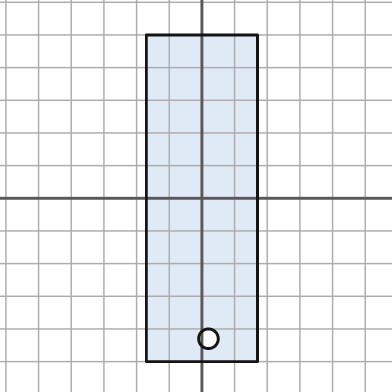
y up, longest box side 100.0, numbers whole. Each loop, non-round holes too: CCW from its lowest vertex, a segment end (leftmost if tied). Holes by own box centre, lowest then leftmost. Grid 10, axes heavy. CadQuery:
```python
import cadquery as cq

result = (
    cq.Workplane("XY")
    .moveTo(-17.0, -50.0)
    .lineTo(17.0, -50.0)
    .lineTo(17.0, 50.0)
    .lineTo(-17.0, 50.0)
    .close()
    .moveTo(2.0, -43.0)
    .circle(3.0)
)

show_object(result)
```